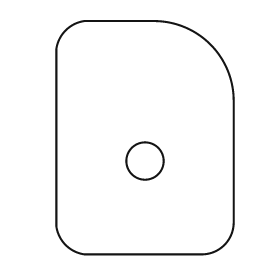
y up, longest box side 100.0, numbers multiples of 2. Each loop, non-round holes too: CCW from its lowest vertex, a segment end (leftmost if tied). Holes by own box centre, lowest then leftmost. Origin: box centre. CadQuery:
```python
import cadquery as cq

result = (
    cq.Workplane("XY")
    .moveTo(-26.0, -50.0)
    .lineTo(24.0, -50.0)
    .threePointArc((34.0, -46.0), (38.0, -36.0))
    .lineTo(38.0, 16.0)
    .threePointArc((28.0, 40.0), (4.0, 50.0))
    .lineTo(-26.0, 50.0)
    .threePointArc((-34.0, 46.0), (-38.0, 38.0))
    .lineTo(-38.0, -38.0)
    .threePointArc((-34.0, -46.0), (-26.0, -50.0))
    .close()
    .moveTo(0.0, -10.0)
    .circle(8.0)
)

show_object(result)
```